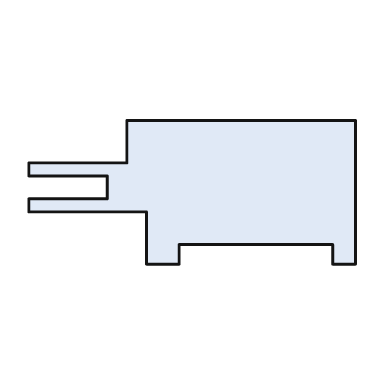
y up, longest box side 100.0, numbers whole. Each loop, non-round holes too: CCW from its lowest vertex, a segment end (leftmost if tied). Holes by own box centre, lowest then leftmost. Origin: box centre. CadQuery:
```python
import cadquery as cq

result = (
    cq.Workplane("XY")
    .moveTo(-14.0, -22.0)
    .lineTo(-4.0, -22.0)
    .lineTo(-4.0, -16.0)
    .lineTo(43.0, -16.0)
    .lineTo(43.0, -22.0)
    .lineTo(50.0, -22.0)
    .lineTo(50.0, 22.0)
    .lineTo(-20.0, 22.0)
    .lineTo(-20.0, 9.0)
    .lineTo(-50.0, 9.0)
    .lineTo(-50.0, 5.0)
    .lineTo(-26.0, 5.0)
    .lineTo(-26.0, -2.0)
    .lineTo(-50.0, -2.0)
    .lineTo(-50.0, -6.0)
    .lineTo(-14.0, -6.0)
    .close()
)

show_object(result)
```